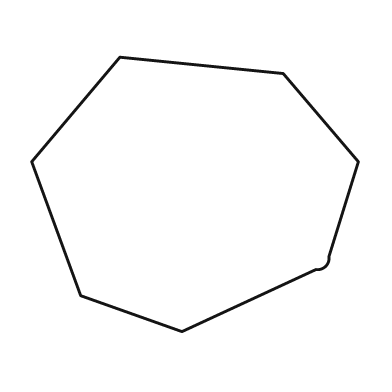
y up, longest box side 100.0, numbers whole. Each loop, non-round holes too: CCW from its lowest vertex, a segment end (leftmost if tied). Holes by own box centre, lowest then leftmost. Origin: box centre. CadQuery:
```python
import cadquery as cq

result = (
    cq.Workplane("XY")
    .moveTo(-4.0, -42.0)
    .lineTo(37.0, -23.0)
    .threePointArc((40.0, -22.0), (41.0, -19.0))
    .lineTo(50.0, 10.0)
    .lineTo(27.0, 37.0)
    .lineTo(-23.0, 42.0)
    .lineTo(-50.0, 10.0)
    .lineTo(-35.0, -31.0)
    .close()
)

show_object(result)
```